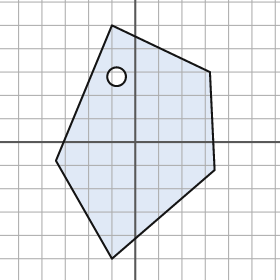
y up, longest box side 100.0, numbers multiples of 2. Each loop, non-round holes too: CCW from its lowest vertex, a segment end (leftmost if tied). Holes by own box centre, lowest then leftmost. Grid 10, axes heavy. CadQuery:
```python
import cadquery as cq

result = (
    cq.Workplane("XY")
    .moveTo(-10.0, -50.0)
    .lineTo(34.0, -12.0)
    .lineTo(32.0, 30.0)
    .lineTo(-10.0, 50.0)
    .lineTo(-34.0, -8.0)
    .close()
    .moveTo(-8.0, 28.0)
    .circle(4.0)
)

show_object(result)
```